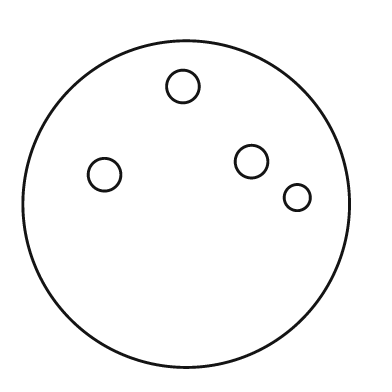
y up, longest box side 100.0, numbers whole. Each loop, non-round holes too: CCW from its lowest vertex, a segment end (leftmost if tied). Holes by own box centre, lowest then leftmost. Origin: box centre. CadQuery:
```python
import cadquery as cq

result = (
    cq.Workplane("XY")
    .moveTo(0.0, 0.0)
    .circle(50.0)
    .moveTo(34.0, 2.0)
    .circle(4.0)
    .moveTo(-25.0, 9.0)
    .circle(5.0)
    .moveTo(20.0, 13.0)
    .circle(5.0)
    .moveTo(-1.0, 36.0)
    .circle(5.0)
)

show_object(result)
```